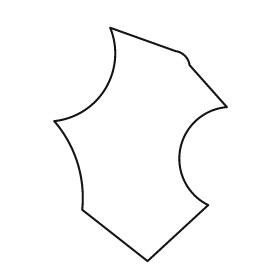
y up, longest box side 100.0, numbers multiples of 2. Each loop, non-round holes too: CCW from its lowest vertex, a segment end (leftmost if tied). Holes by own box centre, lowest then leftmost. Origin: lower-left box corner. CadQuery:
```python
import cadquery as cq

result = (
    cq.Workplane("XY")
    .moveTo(40.0, 0.0)
    .lineTo(66.0, 24.0)
    .threePointArc((54.0, 48.0), (74.0, 66.0))
    .lineTo(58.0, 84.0)
    .threePointArc((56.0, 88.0), (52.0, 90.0))
    .lineTo(24.0, 100.0)
    .threePointArc((22.0, 74.0), (0.0, 60.0))
    .threePointArc((10.0, 42.0), (12.0, 22.0))
    .close()
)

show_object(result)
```